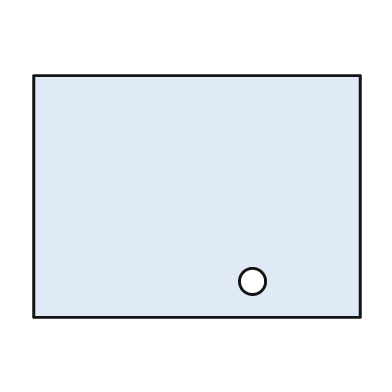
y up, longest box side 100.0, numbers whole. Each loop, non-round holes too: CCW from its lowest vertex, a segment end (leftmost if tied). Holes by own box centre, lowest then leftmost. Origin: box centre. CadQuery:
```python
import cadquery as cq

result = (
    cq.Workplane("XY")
    .moveTo(-50.0, -37.0)
    .lineTo(50.0, -37.0)
    .lineTo(50.0, 37.0)
    .lineTo(-50.0, 37.0)
    .close()
    .moveTo(17.0, -26.0)
    .circle(4.0)
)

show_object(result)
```